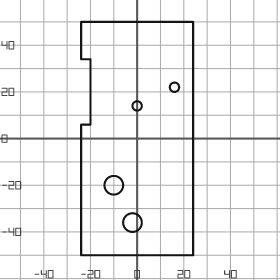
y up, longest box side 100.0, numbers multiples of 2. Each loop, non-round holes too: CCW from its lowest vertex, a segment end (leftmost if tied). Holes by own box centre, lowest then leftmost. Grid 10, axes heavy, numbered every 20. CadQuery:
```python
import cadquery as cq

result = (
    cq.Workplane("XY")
    .moveTo(-24.0, -50.0)
    .lineTo(24.0, -50.0)
    .lineTo(24.0, 50.0)
    .lineTo(-24.0, 50.0)
    .lineTo(-24.0, 34.0)
    .lineTo(-20.0, 34.0)
    .lineTo(-20.0, 6.0)
    .lineTo(-24.0, 6.0)
    .close()
    .moveTo(-2.0, -36.0)
    .circle(4.0)
    .moveTo(-10.0, -20.0)
    .circle(4.0)
    .moveTo(0.0, 14.0)
    .circle(2.0)
    .moveTo(16.0, 22.0)
    .circle(2.0)
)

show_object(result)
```